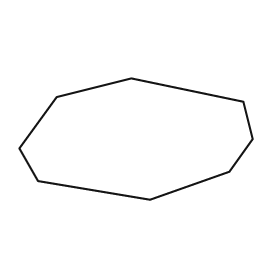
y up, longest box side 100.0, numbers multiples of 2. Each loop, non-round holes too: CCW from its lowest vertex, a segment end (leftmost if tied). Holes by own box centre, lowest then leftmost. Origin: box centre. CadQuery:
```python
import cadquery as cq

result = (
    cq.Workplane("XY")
    .moveTo(6.0, -26.0)
    .lineTo(40.0, -14.0)
    .lineTo(50.0, 0.0)
    .lineTo(46.0, 16.0)
    .lineTo(-2.0, 26.0)
    .lineTo(-34.0, 18.0)
    .lineTo(-50.0, -4.0)
    .lineTo(-42.0, -18.0)
    .close()
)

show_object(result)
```